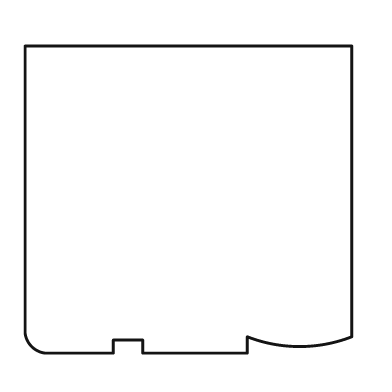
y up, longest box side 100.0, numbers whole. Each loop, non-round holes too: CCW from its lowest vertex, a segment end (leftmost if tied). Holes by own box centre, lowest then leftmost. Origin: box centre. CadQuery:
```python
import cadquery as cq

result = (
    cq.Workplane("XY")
    .moveTo(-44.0, -47.0)
    .lineTo(-23.0, -47.0)
    .lineTo(-23.0, -43.0)
    .lineTo(-14.0, -43.0)
    .lineTo(-14.0, -47.0)
    .lineTo(18.0, -47.0)
    .lineTo(18.0, -42.0)
    .threePointArc((34.0, -45.0), (50.0, -42.0))
    .lineTo(50.0, 47.0)
    .lineTo(-50.0, 47.0)
    .lineTo(-50.0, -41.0)
    .threePointArc((-48.0, -45.0), (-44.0, -47.0))
    .close()
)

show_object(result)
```